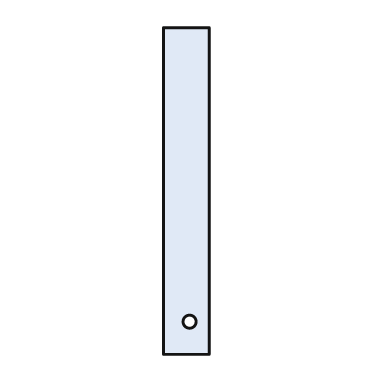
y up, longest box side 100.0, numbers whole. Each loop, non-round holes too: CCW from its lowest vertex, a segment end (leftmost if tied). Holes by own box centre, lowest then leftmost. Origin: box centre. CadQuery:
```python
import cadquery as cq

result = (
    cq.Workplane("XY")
    .moveTo(-7.0, -50.0)
    .lineTo(7.0, -50.0)
    .lineTo(7.0, 50.0)
    .lineTo(-7.0, 50.0)
    .close()
    .moveTo(1.0, -40.0)
    .circle(2.0)
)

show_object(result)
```